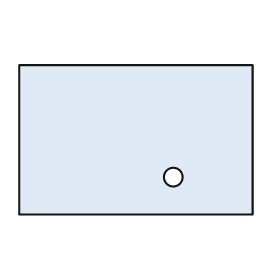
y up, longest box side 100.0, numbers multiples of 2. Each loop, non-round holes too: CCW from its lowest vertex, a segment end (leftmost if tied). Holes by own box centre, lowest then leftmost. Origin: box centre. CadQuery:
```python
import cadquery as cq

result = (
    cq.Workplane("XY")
    .moveTo(-50.0, -32.0)
    .lineTo(50.0, -32.0)
    .lineTo(50.0, 32.0)
    .lineTo(-50.0, 32.0)
    .close()
    .moveTo(16.0, -16.0)
    .circle(4.0)
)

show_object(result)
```